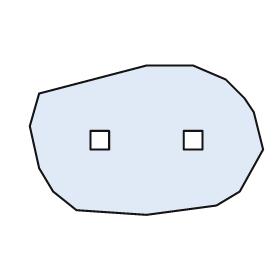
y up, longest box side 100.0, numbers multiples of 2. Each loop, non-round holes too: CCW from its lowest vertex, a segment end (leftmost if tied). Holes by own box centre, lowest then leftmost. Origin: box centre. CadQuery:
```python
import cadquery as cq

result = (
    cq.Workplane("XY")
    .moveTo(0.0, -32.0)
    .lineTo(30.0, -28.0)
    .lineTo(40.0, -22.0)
    .lineTo(50.0, -4.0)
    .lineTo(46.0, 12.0)
    .lineTo(42.0, 18.0)
    .lineTo(34.0, 26.0)
    .lineTo(20.0, 32.0)
    .lineTo(0.0, 32.0)
    .lineTo(-46.0, 20.0)
    .lineTo(-50.0, 6.0)
    .lineTo(-46.0, -12.0)
    .lineTo(-40.0, -22.0)
    .lineTo(-30.0, -30.0)
    .close()
    .moveTo(-24.0, -4.0)
    .lineTo(-16.0, -4.0)
    .lineTo(-16.0, 4.0)
    .lineTo(-24.0, 4.0)
    .close()
    .moveTo(16.0, -4.0)
    .lineTo(24.0, -4.0)
    .lineTo(24.0, 4.0)
    .lineTo(16.0, 4.0)
    .close()
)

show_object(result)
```